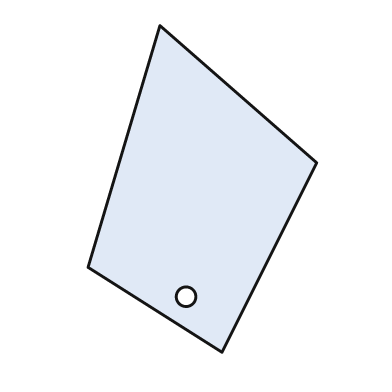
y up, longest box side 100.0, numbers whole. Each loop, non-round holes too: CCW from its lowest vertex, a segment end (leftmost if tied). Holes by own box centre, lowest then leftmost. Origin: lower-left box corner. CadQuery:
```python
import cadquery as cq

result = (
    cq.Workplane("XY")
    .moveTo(41.0, 0.0)
    .lineTo(70.0, 58.0)
    .lineTo(22.0, 100.0)
    .lineTo(0.0, 26.0)
    .close()
    .moveTo(30.0, 17.0)
    .circle(3.0)
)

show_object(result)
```